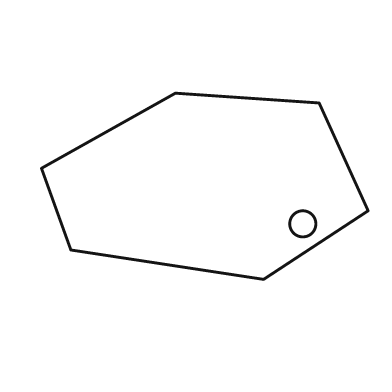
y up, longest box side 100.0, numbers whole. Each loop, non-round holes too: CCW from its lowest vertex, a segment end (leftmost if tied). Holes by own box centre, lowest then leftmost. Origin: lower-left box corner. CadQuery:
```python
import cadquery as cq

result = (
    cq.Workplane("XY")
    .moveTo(68.0, 0.0)
    .lineTo(100.0, 21.0)
    .lineTo(85.0, 54.0)
    .lineTo(41.0, 57.0)
    .lineTo(0.0, 34.0)
    .lineTo(9.0, 9.0)
    .close()
    .moveTo(80.0, 17.0)
    .circle(4.0)
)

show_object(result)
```